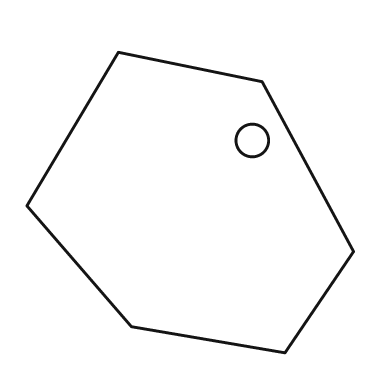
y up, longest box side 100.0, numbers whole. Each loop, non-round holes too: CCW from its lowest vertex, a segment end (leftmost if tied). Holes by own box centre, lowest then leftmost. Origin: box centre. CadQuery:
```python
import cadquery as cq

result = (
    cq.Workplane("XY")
    .moveTo(29.0, -46.0)
    .lineTo(50.0, -15.0)
    .lineTo(22.0, 37.0)
    .lineTo(-22.0, 46.0)
    .lineTo(-50.0, -1.0)
    .lineTo(-18.0, -38.0)
    .close()
    .moveTo(19.0, 19.0)
    .circle(5.0)
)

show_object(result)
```